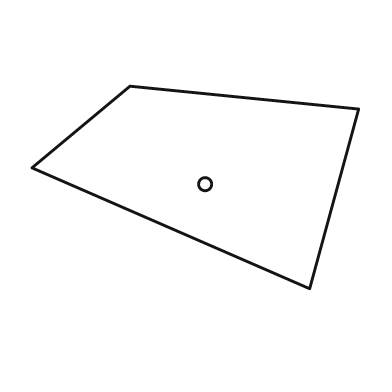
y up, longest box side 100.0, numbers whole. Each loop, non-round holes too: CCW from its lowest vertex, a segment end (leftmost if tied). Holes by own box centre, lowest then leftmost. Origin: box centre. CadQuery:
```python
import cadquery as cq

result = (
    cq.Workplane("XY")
    .moveTo(35.0, -31.0)
    .lineTo(50.0, 24.0)
    .lineTo(-20.0, 31.0)
    .lineTo(-50.0, 6.0)
    .close()
    .moveTo(3.0, 1.0)
    .circle(2.0)
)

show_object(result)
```